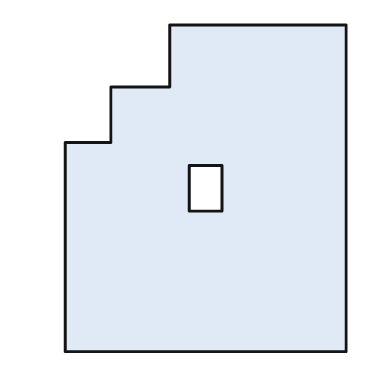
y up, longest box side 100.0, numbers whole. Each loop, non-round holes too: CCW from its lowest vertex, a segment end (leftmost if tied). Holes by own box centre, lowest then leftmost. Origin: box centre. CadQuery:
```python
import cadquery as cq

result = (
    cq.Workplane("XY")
    .moveTo(-43.0, -50.0)
    .lineTo(43.0, -50.0)
    .lineTo(43.0, 50.0)
    .lineTo(-11.0, 50.0)
    .lineTo(-11.0, 31.0)
    .lineTo(-29.0, 31.0)
    .lineTo(-29.0, 14.0)
    .lineTo(-43.0, 14.0)
    .close()
    .moveTo(-5.0, -7.0)
    .lineTo(5.0, -7.0)
    .lineTo(5.0, 7.0)
    .lineTo(-5.0, 7.0)
    .close()
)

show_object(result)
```